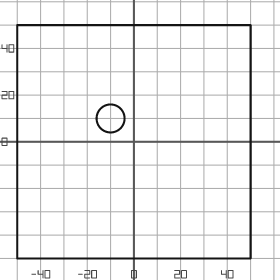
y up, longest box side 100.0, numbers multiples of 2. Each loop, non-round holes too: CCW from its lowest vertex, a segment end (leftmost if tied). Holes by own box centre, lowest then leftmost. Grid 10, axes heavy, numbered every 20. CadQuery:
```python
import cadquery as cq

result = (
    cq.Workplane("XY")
    .moveTo(-50.0, -50.0)
    .lineTo(50.0, -50.0)
    .lineTo(50.0, 50.0)
    .lineTo(-50.0, 50.0)
    .close()
    .moveTo(-10.0, 10.0)
    .circle(6.0)
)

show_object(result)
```